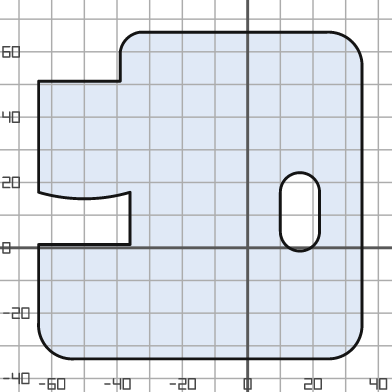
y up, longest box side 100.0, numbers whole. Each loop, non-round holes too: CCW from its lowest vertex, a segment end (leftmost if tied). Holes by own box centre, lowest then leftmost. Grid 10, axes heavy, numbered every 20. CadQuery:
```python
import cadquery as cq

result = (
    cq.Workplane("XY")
    .moveTo(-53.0, -34.0)
    .lineTo(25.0, -34.0)
    .threePointArc((32.0, -31.0), (35.0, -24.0))
    .lineTo(35.0, 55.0)
    .threePointArc((32.0, 63.0), (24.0, 66.0))
    .lineTo(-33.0, 66.0)
    .threePointArc((-37.0, 64.0), (-39.0, 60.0))
    .lineTo(-39.0, 51.0)
    .lineTo(-64.0, 51.0)
    .lineTo(-64.0, 17.0)
    .threePointArc((-50.0, 15.0), (-36.0, 17.0))
    .lineTo(-36.0, 1.0)
    .lineTo(-64.0, 1.0)
    .lineTo(-64.0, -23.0)
    .threePointArc((-61.0, -31.0), (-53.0, -34.0))
    .close()
    .moveTo(10.0, 5.0)
    .threePointArc((16.0, -1.0), (22.0, 5.0))
    .lineTo(22.0, 17.0)
    .threePointArc((16.0, 23.0), (10.0, 17.0))
    .close()
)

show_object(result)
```